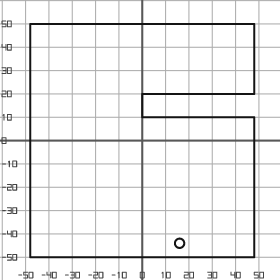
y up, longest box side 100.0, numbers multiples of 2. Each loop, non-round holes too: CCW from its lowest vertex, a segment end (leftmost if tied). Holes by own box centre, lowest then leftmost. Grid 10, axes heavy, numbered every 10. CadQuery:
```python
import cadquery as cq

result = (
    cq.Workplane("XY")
    .moveTo(-48.0, -50.0)
    .lineTo(48.0, -50.0)
    .lineTo(48.0, 10.0)
    .lineTo(0.0, 10.0)
    .lineTo(0.0, 20.0)
    .lineTo(48.0, 20.0)
    .lineTo(48.0, 50.0)
    .lineTo(-48.0, 50.0)
    .close()
    .moveTo(16.0, -44.0)
    .circle(2.0)
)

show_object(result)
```